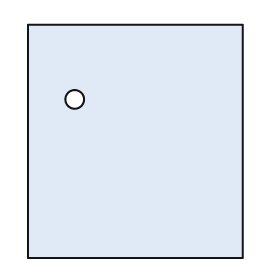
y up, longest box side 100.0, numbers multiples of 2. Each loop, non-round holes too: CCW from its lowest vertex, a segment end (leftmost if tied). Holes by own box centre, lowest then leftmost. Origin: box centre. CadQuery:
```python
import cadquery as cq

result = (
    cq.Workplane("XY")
    .moveTo(-46.0, -50.0)
    .lineTo(46.0, -50.0)
    .lineTo(46.0, 50.0)
    .lineTo(-46.0, 50.0)
    .close()
    .moveTo(-26.0, 18.0)
    .circle(4.0)
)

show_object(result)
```